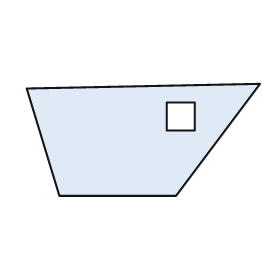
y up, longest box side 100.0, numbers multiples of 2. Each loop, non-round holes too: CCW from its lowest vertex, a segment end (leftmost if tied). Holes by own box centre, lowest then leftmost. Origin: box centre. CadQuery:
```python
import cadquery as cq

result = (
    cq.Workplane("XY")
    .moveTo(-36.0, -24.0)
    .lineTo(14.0, -24.0)
    .lineTo(50.0, 24.0)
    .lineTo(-50.0, 22.0)
    .close()
    .moveTo(10.0, 4.0)
    .lineTo(22.0, 4.0)
    .lineTo(22.0, 16.0)
    .lineTo(10.0, 16.0)
    .close()
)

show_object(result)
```